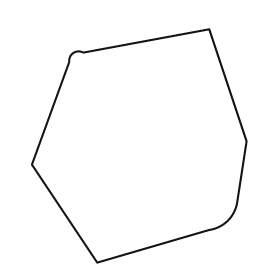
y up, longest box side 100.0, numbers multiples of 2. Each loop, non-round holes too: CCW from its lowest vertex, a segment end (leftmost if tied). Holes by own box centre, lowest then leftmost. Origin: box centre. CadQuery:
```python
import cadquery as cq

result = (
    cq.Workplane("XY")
    .moveTo(-18.0, -50.0)
    .lineTo(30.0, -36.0)
    .threePointArc((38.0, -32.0), (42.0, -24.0))
    .lineTo(46.0, 2.0)
    .lineTo(30.0, 50.0)
    .lineTo(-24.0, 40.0)
    .threePointArc((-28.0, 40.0), (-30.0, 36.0))
    .lineTo(-46.0, -8.0)
    .close()
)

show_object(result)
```